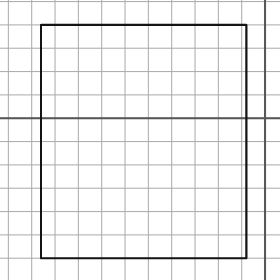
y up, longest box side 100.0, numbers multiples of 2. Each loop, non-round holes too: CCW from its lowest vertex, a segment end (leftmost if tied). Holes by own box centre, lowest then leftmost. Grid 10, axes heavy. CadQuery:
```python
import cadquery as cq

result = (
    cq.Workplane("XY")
    .moveTo(-96.0, -60.0)
    .lineTo(-8.0, -60.0)
    .lineTo(-8.0, 40.0)
    .lineTo(-96.0, 40.0)
    .close()
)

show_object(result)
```